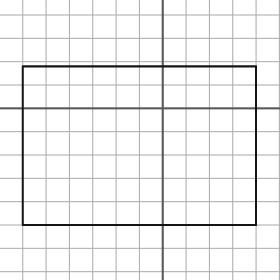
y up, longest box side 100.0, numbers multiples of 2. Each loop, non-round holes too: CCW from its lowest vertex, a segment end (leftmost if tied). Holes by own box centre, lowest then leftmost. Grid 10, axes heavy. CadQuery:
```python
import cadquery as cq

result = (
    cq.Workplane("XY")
    .moveTo(-60.0, -50.0)
    .lineTo(40.0, -50.0)
    .lineTo(40.0, 18.0)
    .lineTo(-60.0, 18.0)
    .close()
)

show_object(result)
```